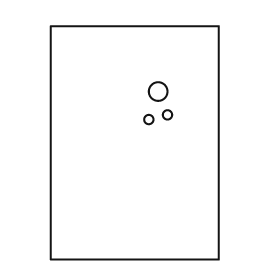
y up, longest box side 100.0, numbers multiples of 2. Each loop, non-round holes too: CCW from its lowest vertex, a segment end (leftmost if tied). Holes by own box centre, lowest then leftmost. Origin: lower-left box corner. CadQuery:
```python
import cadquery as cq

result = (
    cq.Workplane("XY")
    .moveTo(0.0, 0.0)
    .lineTo(72.0, 0.0)
    .lineTo(72.0, 100.0)
    .lineTo(0.0, 100.0)
    .close()
    .moveTo(42.0, 60.0)
    .circle(2.0)
    .moveTo(50.0, 62.0)
    .circle(2.0)
    .moveTo(46.0, 72.0)
    .circle(4.0)
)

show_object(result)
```